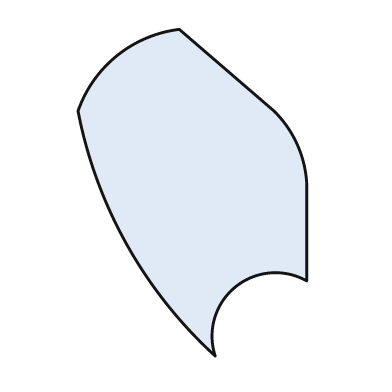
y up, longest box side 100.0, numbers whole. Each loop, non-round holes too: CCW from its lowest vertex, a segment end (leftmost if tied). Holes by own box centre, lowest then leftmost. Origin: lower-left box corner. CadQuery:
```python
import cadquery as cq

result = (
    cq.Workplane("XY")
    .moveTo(42.0, 0.0)
    .threePointArc((48.0, 21.0), (70.0, 23.0))
    .lineTo(70.0, 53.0)
    .threePointArc((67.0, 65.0), (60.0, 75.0))
    .lineTo(31.0, 100.0)
    .threePointArc((12.0, 92.0), (0.0, 75.0))
    .threePointArc((15.0, 34.0), (42.0, 0.0))
    .close()
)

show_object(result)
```